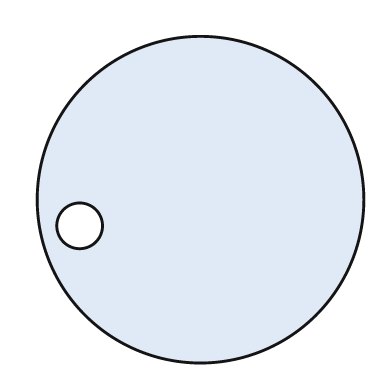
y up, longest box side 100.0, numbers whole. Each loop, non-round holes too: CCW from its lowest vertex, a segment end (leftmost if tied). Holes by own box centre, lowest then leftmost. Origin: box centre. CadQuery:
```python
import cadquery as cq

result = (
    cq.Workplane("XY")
    .moveTo(0.0, 0.0)
    .circle(50.0)
    .moveTo(-37.0, -8.0)
    .circle(7.0)
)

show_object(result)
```